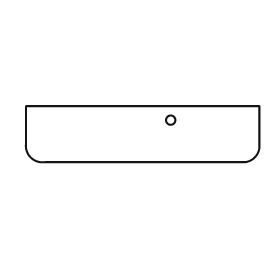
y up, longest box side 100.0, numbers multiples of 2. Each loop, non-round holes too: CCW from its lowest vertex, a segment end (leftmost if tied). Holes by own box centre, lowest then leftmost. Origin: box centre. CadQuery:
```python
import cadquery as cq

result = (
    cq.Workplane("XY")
    .moveTo(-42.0, -12.0)
    .lineTo(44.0, -12.0)
    .threePointArc((48.0, -10.0), (50.0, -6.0))
    .lineTo(50.0, 12.0)
    .lineTo(-50.0, 12.0)
    .lineTo(-50.0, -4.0)
    .threePointArc((-48.0, -10.0), (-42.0, -12.0))
    .close()
    .moveTo(12.0, 6.0)
    .circle(2.0)
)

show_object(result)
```